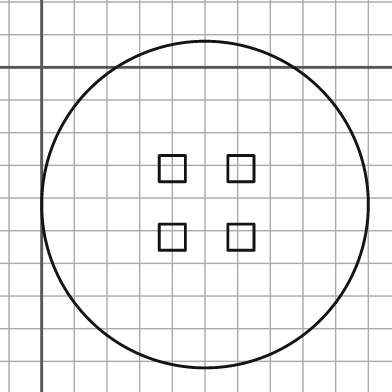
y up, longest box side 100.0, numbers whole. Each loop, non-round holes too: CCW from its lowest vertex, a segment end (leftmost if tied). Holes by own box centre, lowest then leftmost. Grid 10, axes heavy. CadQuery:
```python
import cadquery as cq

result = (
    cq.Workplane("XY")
    .moveTo(50.0, -42.0)
    .circle(50.0)
    .moveTo(36.0, -56.0)
    .lineTo(44.0, -56.0)
    .lineTo(44.0, -48.0)
    .lineTo(36.0, -48.0)
    .close()
    .moveTo(57.0, -56.0)
    .lineTo(65.0, -56.0)
    .lineTo(65.0, -48.0)
    .lineTo(57.0, -48.0)
    .close()
    .moveTo(36.0, -35.0)
    .lineTo(44.0, -35.0)
    .lineTo(44.0, -27.0)
    .lineTo(36.0, -27.0)
    .close()
    .moveTo(57.0, -35.0)
    .lineTo(65.0, -35.0)
    .lineTo(65.0, -27.0)
    .lineTo(57.0, -27.0)
    .close()
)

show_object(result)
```